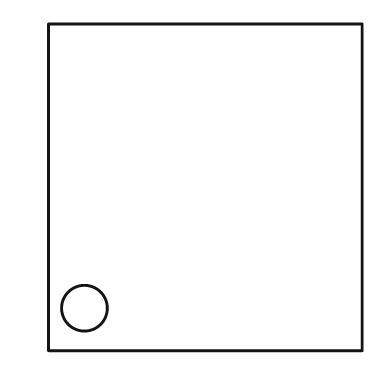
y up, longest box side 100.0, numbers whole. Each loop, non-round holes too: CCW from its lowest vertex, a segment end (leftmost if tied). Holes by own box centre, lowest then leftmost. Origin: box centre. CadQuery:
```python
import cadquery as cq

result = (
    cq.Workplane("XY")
    .moveTo(-48.0, -50.0)
    .lineTo(48.0, -50.0)
    .lineTo(48.0, 50.0)
    .lineTo(-48.0, 50.0)
    .close()
    .moveTo(-37.0, -37.0)
    .circle(7.0)
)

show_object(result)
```